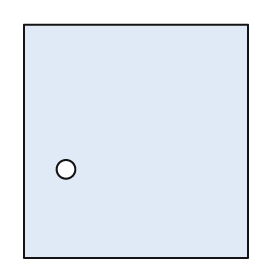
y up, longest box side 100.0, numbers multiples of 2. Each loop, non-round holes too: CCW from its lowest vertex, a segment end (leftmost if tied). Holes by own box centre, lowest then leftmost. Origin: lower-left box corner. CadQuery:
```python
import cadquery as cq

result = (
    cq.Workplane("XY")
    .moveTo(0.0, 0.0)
    .lineTo(96.0, 0.0)
    .lineTo(96.0, 100.0)
    .lineTo(0.0, 100.0)
    .close()
    .moveTo(18.0, 38.0)
    .circle(4.0)
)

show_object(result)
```